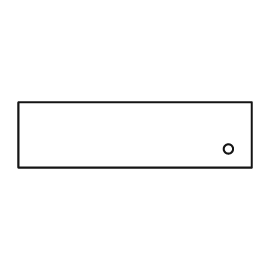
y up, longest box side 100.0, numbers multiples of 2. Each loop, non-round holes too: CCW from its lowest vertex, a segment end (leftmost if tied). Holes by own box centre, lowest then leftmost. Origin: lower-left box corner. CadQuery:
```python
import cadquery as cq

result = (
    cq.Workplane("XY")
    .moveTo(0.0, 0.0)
    .lineTo(100.0, 0.0)
    .lineTo(100.0, 28.0)
    .lineTo(0.0, 28.0)
    .close()
    .moveTo(90.0, 8.0)
    .circle(2.0)
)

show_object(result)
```